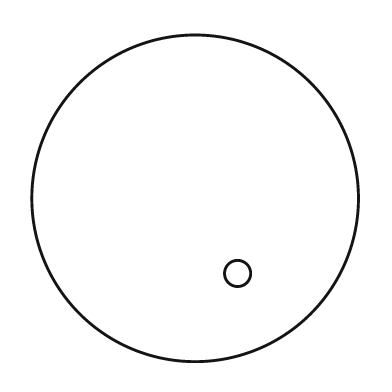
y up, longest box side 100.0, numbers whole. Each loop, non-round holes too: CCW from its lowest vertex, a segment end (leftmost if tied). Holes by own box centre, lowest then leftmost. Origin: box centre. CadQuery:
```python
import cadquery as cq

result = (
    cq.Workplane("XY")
    .moveTo(0.0, 0.0)
    .circle(50.0)
    .moveTo(13.0, -23.0)
    .circle(4.0)
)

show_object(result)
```